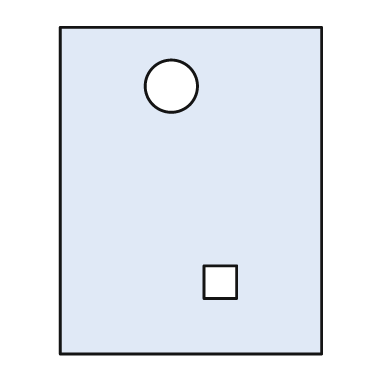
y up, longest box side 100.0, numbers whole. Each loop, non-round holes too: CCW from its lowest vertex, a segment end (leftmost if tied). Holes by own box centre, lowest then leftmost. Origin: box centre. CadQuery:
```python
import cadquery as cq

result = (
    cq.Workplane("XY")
    .moveTo(-40.0, -50.0)
    .lineTo(40.0, -50.0)
    .lineTo(40.0, 50.0)
    .lineTo(-40.0, 50.0)
    .close()
    .moveTo(4.0, -33.0)
    .lineTo(14.0, -33.0)
    .lineTo(14.0, -23.0)
    .lineTo(4.0, -23.0)
    .close()
    .moveTo(-6.0, 32.0)
    .circle(8.0)
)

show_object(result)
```